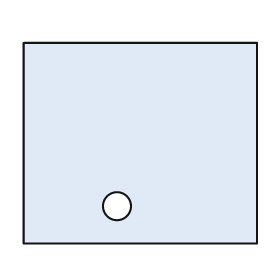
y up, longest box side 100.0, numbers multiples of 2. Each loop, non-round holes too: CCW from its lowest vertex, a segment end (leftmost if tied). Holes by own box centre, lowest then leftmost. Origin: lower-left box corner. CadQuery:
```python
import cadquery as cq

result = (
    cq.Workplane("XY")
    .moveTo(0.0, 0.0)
    .lineTo(100.0, 0.0)
    .lineTo(100.0, 86.0)
    .lineTo(0.0, 86.0)
    .close()
    .moveTo(40.0, 16.0)
    .circle(6.0)
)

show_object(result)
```